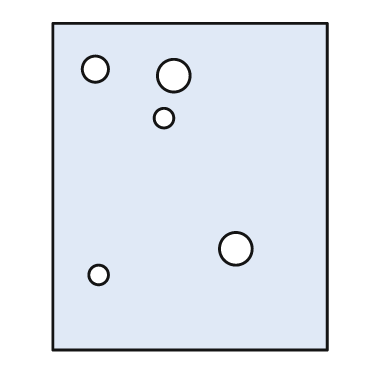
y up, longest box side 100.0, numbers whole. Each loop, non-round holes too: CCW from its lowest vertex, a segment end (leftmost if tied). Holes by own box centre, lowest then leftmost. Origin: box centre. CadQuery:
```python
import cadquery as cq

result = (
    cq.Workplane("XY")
    .moveTo(-42.0, -50.0)
    .lineTo(42.0, -50.0)
    .lineTo(42.0, 50.0)
    .lineTo(-42.0, 50.0)
    .close()
    .moveTo(-28.0, -27.0)
    .circle(3.0)
    .moveTo(14.0, -19.0)
    .circle(5.0)
    .moveTo(-8.0, 21.0)
    .circle(3.0)
    .moveTo(-5.0, 34.0)
    .circle(5.0)
    .moveTo(-29.0, 36.0)
    .circle(4.0)
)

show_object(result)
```